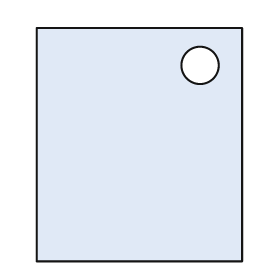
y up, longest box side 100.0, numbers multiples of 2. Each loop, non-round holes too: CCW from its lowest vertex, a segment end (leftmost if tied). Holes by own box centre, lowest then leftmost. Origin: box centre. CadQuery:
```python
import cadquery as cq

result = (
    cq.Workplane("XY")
    .moveTo(-44.0, -50.0)
    .lineTo(44.0, -50.0)
    .lineTo(44.0, 50.0)
    .lineTo(-44.0, 50.0)
    .close()
    .moveTo(26.0, 34.0)
    .circle(8.0)
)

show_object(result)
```